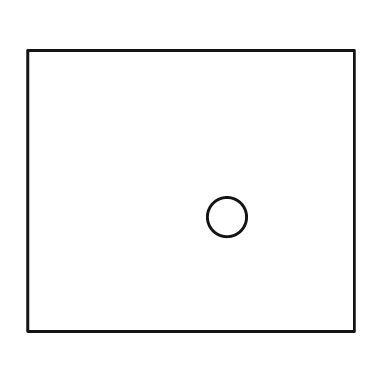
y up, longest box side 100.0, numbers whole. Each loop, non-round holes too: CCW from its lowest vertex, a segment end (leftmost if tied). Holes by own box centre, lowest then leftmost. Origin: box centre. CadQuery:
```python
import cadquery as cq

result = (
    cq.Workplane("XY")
    .moveTo(-50.0, -43.0)
    .lineTo(50.0, -43.0)
    .lineTo(50.0, 43.0)
    .lineTo(-50.0, 43.0)
    .close()
    .moveTo(11.0, -8.0)
    .circle(6.0)
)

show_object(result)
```